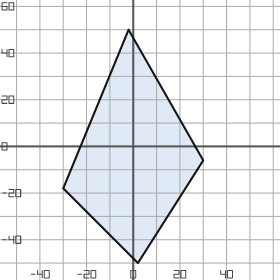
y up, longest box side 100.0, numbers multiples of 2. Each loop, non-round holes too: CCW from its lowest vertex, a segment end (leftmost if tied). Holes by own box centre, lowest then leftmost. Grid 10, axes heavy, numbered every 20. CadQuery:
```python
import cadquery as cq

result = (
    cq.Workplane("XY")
    .moveTo(2.0, -50.0)
    .lineTo(30.0, -6.0)
    .lineTo(-2.0, 50.0)
    .lineTo(-30.0, -18.0)
    .close()
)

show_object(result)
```